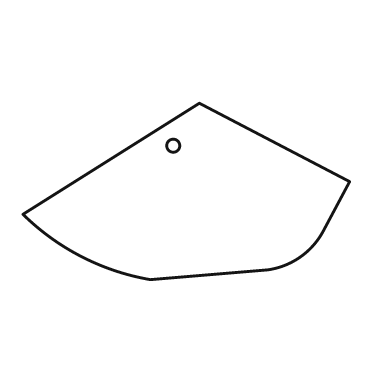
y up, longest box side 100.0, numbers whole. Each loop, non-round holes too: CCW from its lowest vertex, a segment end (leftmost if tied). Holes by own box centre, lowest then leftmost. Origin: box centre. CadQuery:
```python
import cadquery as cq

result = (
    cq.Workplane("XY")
    .moveTo(-11.0, -27.0)
    .lineTo(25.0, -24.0)
    .threePointArc((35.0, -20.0), (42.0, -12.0))
    .lineTo(50.0, 3.0)
    .lineTo(4.0, 27.0)
    .lineTo(-50.0, -7.0)
    .threePointArc((-32.0, -20.0), (-11.0, -27.0))
    .close()
    .moveTo(-4.0, 14.0)
    .circle(2.0)
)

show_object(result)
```